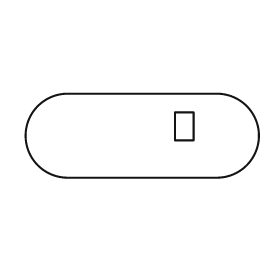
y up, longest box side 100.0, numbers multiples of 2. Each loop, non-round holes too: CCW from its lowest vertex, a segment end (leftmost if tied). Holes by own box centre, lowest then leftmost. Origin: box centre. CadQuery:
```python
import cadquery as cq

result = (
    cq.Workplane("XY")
    .moveTo(-32.0, -18.0)
    .lineTo(32.0, -18.0)
    .threePointArc((50.0, 0.0), (32.0, 18.0))
    .lineTo(-32.0, 18.0)
    .threePointArc((-50.0, 0.0), (-32.0, -18.0))
    .close()
    .moveTo(14.0, -2.0)
    .lineTo(22.0, -2.0)
    .lineTo(22.0, 10.0)
    .lineTo(14.0, 10.0)
    .close()
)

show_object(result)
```